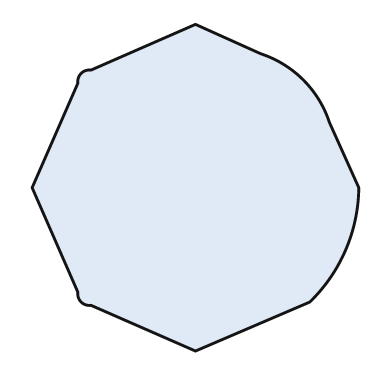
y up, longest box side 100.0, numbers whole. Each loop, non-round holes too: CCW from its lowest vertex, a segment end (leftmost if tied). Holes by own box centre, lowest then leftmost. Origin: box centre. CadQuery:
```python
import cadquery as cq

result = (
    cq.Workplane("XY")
    .moveTo(0.0, -50.0)
    .lineTo(35.0, -35.0)
    .threePointArc((46.0, -19.0), (50.0, 0.0))
    .lineTo(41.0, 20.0)
    .threePointArc((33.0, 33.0), (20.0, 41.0))
    .lineTo(0.0, 50.0)
    .lineTo(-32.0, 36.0)
    .threePointArc((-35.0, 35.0), (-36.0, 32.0))
    .lineTo(-50.0, 0.0)
    .lineTo(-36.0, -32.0)
    .threePointArc((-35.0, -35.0), (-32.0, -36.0))
    .close()
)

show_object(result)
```